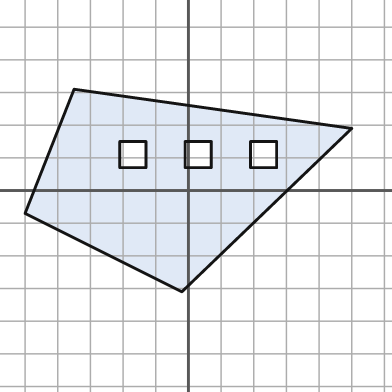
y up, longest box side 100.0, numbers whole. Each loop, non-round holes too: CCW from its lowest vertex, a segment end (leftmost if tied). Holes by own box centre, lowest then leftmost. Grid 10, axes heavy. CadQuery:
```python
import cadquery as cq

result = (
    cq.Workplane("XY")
    .moveTo(-2.0, -31.0)
    .lineTo(50.0, 19.0)
    .lineTo(-35.0, 31.0)
    .lineTo(-50.0, -7.0)
    .close()
    .moveTo(-21.0, 7.0)
    .lineTo(-13.0, 7.0)
    .lineTo(-13.0, 15.0)
    .lineTo(-21.0, 15.0)
    .close()
    .moveTo(-1.0, 7.0)
    .lineTo(7.0, 7.0)
    .lineTo(7.0, 15.0)
    .lineTo(-1.0, 15.0)
    .close()
    .moveTo(19.0, 7.0)
    .lineTo(27.0, 7.0)
    .lineTo(27.0, 15.0)
    .lineTo(19.0, 15.0)
    .close()
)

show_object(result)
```